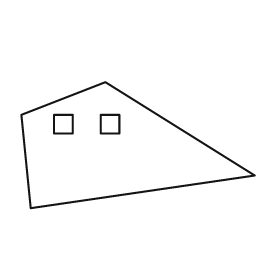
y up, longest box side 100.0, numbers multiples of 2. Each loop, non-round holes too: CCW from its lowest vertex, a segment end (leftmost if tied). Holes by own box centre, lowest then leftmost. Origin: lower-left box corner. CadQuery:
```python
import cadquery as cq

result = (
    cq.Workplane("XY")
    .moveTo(4.0, 0.0)
    .lineTo(100.0, 14.0)
    .lineTo(36.0, 54.0)
    .lineTo(0.0, 40.0)
    .close()
    .moveTo(14.0, 32.0)
    .lineTo(22.0, 32.0)
    .lineTo(22.0, 40.0)
    .lineTo(14.0, 40.0)
    .close()
    .moveTo(34.0, 32.0)
    .lineTo(42.0, 32.0)
    .lineTo(42.0, 40.0)
    .lineTo(34.0, 40.0)
    .close()
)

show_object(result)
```